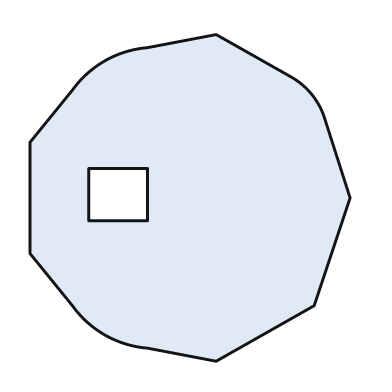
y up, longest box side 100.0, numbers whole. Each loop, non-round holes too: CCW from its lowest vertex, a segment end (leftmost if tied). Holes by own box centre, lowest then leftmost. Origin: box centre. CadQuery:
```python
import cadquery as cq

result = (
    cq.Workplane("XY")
    .moveTo(8.0, -50.0)
    .lineTo(38.0, -33.0)
    .lineTo(49.0, 0.0)
    .lineTo(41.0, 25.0)
    .threePointArc((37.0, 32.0), (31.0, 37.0))
    .lineTo(8.0, 50.0)
    .lineTo(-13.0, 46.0)
    .threePointArc((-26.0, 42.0), (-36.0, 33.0))
    .lineTo(-49.0, 17.0)
    .lineTo(-49.0, -17.0)
    .lineTo(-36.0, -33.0)
    .threePointArc((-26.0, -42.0), (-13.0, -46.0))
    .close()
    .moveTo(-31.0, -7.0)
    .lineTo(-13.0, -7.0)
    .lineTo(-13.0, 9.0)
    .lineTo(-31.0, 9.0)
    .close()
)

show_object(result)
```